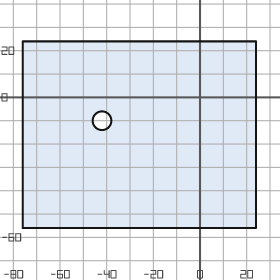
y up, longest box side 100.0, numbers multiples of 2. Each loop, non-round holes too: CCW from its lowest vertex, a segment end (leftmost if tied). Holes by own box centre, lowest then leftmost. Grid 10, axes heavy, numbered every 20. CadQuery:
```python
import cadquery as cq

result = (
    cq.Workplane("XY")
    .moveTo(-76.0, -56.0)
    .lineTo(24.0, -56.0)
    .lineTo(24.0, 24.0)
    .lineTo(-76.0, 24.0)
    .close()
    .moveTo(-42.0, -10.0)
    .circle(4.0)
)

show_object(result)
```